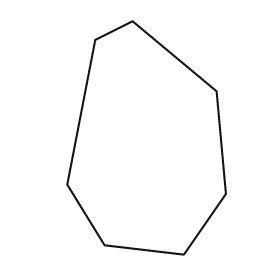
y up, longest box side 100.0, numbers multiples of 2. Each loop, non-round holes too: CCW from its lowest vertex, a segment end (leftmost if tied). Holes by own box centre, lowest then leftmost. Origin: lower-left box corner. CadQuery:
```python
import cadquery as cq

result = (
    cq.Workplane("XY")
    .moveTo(50.0, 0.0)
    .lineTo(68.0, 26.0)
    .lineTo(64.0, 70.0)
    .lineTo(28.0, 100.0)
    .lineTo(12.0, 92.0)
    .lineTo(0.0, 30.0)
    .lineTo(16.0, 4.0)
    .close()
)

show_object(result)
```